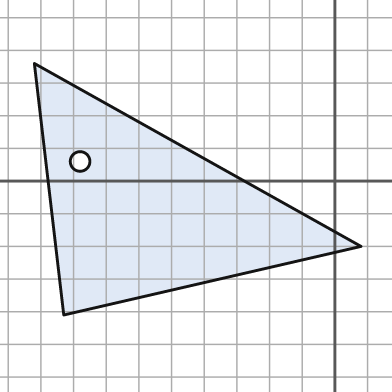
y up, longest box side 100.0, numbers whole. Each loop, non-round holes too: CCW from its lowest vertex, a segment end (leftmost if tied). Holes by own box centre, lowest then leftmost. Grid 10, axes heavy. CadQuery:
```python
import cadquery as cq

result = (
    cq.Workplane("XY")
    .moveTo(-83.0, -41.0)
    .lineTo(8.0, -20.0)
    .lineTo(-92.0, 36.0)
    .close()
    .moveTo(-78.0, 6.0)
    .circle(3.0)
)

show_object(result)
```